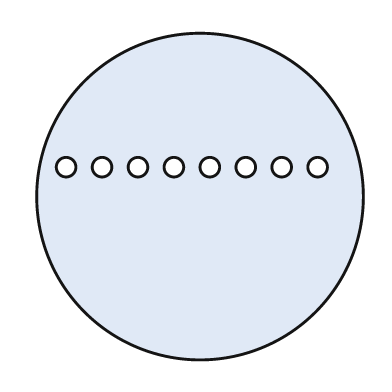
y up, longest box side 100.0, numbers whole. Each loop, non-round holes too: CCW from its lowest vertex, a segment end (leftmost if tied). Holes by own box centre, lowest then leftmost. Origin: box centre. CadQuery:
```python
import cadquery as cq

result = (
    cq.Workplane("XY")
    .moveTo(0.0, 0.0)
    .circle(50.0)
    .moveTo(-41.0, 9.0)
    .circle(3.0)
    .moveTo(-30.0, 9.0)
    .circle(3.0)
    .moveTo(-19.0, 9.0)
    .circle(3.0)
    .moveTo(-8.0, 9.0)
    .circle(3.0)
    .moveTo(3.0, 9.0)
    .circle(3.0)
    .moveTo(14.0, 9.0)
    .circle(3.0)
    .moveTo(25.0, 9.0)
    .circle(3.0)
    .moveTo(36.0, 9.0)
    .circle(3.0)
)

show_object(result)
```